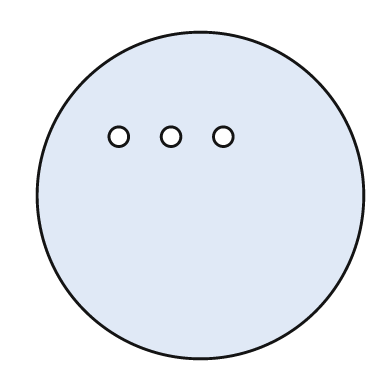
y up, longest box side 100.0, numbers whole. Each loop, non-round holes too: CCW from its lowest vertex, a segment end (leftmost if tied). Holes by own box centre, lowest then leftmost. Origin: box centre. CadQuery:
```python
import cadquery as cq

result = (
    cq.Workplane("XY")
    .moveTo(0.0, 0.0)
    .circle(50.0)
    .moveTo(-25.0, 18.0)
    .circle(3.0)
    .moveTo(-9.0, 18.0)
    .circle(3.0)
    .moveTo(7.0, 18.0)
    .circle(3.0)
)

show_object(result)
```